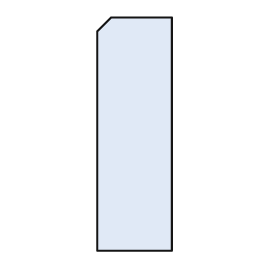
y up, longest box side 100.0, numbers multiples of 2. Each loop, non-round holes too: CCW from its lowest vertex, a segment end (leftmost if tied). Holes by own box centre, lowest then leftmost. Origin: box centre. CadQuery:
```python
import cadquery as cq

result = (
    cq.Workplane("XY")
    .moveTo(-16.0, -50.0)
    .lineTo(16.0, -50.0)
    .lineTo(16.0, 50.0)
    .lineTo(-10.0, 50.0)
    .lineTo(-16.0, 44.0)
    .close()
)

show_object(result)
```